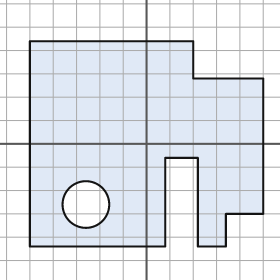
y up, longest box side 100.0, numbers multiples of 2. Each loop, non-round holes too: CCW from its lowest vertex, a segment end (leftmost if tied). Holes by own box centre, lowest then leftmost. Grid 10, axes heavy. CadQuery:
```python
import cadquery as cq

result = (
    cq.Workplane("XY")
    .moveTo(-50.0, -44.0)
    .lineTo(8.0, -44.0)
    .lineTo(8.0, -6.0)
    .lineTo(22.0, -6.0)
    .lineTo(22.0, -44.0)
    .lineTo(34.0, -44.0)
    .lineTo(34.0, -30.0)
    .lineTo(50.0, -30.0)
    .lineTo(50.0, 28.0)
    .lineTo(20.0, 28.0)
    .lineTo(20.0, 44.0)
    .lineTo(-50.0, 44.0)
    .close()
    .moveTo(-26.0, -26.0)
    .circle(10.0)
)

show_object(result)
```